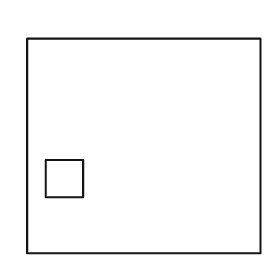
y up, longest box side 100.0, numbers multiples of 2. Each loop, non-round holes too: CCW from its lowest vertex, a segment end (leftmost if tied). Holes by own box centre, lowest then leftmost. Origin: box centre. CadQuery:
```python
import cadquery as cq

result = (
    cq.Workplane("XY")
    .moveTo(-50.0, -46.0)
    .lineTo(50.0, -46.0)
    .lineTo(50.0, 46.0)
    .lineTo(-50.0, 46.0)
    .close()
    .moveTo(-42.0, -22.0)
    .lineTo(-26.0, -22.0)
    .lineTo(-26.0, -6.0)
    .lineTo(-42.0, -6.0)
    .close()
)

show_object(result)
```